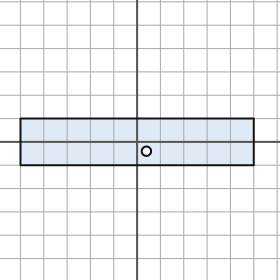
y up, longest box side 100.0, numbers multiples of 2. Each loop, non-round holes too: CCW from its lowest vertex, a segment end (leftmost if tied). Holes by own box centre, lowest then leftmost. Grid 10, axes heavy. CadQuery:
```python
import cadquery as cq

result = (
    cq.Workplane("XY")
    .moveTo(-50.0, -10.0)
    .lineTo(50.0, -10.0)
    .lineTo(50.0, 10.0)
    .lineTo(-50.0, 10.0)
    .close()
    .moveTo(4.0, -4.0)
    .circle(2.0)
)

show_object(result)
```